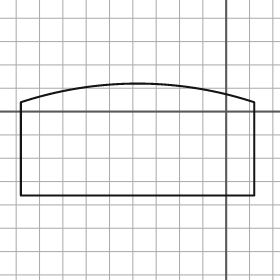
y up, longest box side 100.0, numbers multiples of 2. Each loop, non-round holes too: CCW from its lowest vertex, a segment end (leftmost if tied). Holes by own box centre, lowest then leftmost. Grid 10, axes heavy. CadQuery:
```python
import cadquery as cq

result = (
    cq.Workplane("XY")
    .moveTo(-88.0, -36.0)
    .lineTo(12.0, -36.0)
    .lineTo(12.0, 4.0)
    .threePointArc((-38.0, 12.0), (-88.0, 4.0))
    .close()
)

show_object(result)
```